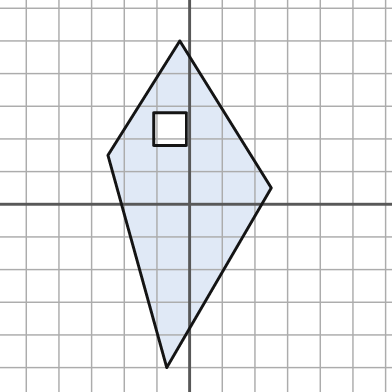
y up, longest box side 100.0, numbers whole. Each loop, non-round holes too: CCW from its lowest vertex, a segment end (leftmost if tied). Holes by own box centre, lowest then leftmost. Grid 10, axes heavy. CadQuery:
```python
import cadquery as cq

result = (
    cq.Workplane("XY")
    .moveTo(-7.0, -50.0)
    .lineTo(25.0, 5.0)
    .lineTo(-3.0, 50.0)
    .lineTo(-25.0, 15.0)
    .close()
    .moveTo(-11.0, 18.0)
    .lineTo(-1.0, 18.0)
    .lineTo(-1.0, 28.0)
    .lineTo(-11.0, 28.0)
    .close()
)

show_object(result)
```